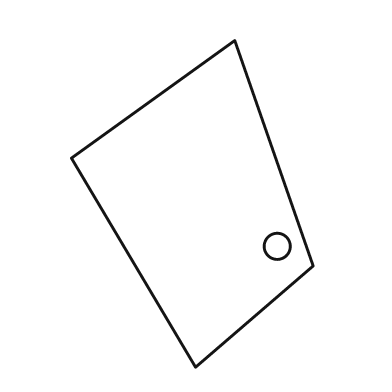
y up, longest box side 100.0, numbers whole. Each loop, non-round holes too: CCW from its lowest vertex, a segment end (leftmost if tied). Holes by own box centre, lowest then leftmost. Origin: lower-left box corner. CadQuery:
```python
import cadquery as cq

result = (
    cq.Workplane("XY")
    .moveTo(38.0, 0.0)
    .lineTo(74.0, 31.0)
    .lineTo(50.0, 100.0)
    .lineTo(0.0, 64.0)
    .close()
    .moveTo(63.0, 37.0)
    .circle(4.0)
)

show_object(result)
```